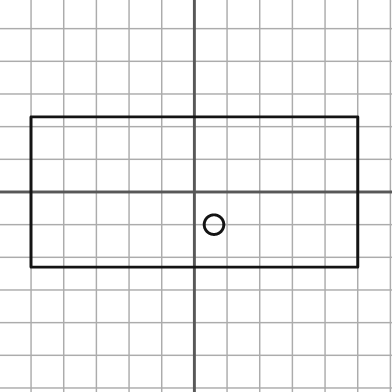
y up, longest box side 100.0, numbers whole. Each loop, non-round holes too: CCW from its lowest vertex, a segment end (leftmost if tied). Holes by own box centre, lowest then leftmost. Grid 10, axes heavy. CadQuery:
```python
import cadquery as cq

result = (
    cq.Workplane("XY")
    .moveTo(-50.0, -23.0)
    .lineTo(50.0, -23.0)
    .lineTo(50.0, 23.0)
    .lineTo(-50.0, 23.0)
    .close()
    .moveTo(6.0, -10.0)
    .circle(3.0)
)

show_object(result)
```